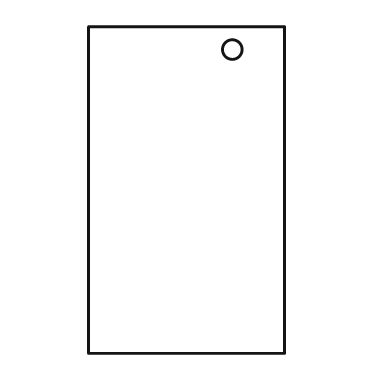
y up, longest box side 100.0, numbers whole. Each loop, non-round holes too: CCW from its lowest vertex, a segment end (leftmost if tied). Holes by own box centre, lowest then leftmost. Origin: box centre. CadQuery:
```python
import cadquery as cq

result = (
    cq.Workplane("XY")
    .moveTo(-30.0, -50.0)
    .lineTo(30.0, -50.0)
    .lineTo(30.0, 50.0)
    .lineTo(-30.0, 50.0)
    .close()
    .moveTo(14.0, 43.0)
    .circle(3.0)
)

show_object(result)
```